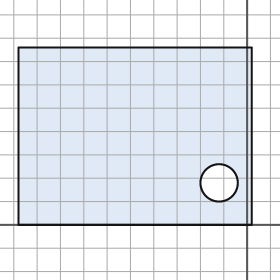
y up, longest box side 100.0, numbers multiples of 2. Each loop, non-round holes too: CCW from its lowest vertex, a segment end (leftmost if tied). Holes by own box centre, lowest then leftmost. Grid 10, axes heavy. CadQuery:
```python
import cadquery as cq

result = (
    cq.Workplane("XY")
    .moveTo(-98.0, 0.0)
    .lineTo(2.0, 0.0)
    .lineTo(2.0, 76.0)
    .lineTo(-98.0, 76.0)
    .close()
    .moveTo(-12.0, 18.0)
    .circle(8.0)
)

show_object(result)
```